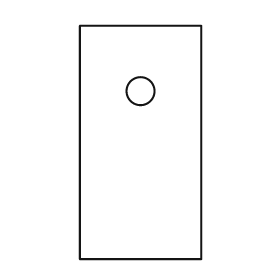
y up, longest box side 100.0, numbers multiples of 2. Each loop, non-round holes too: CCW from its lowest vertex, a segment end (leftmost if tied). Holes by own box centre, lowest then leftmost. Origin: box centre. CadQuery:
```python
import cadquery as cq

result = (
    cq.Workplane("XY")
    .moveTo(-26.0, -50.0)
    .lineTo(26.0, -50.0)
    .lineTo(26.0, 50.0)
    .lineTo(-26.0, 50.0)
    .close()
    .moveTo(0.0, 22.0)
    .circle(6.0)
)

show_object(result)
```